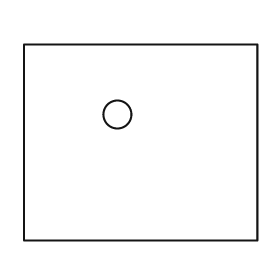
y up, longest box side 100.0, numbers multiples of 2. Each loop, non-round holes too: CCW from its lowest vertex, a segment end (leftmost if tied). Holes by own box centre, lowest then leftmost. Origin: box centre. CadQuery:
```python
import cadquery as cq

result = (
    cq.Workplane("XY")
    .moveTo(-50.0, -42.0)
    .lineTo(50.0, -42.0)
    .lineTo(50.0, 42.0)
    .lineTo(-50.0, 42.0)
    .close()
    .moveTo(-10.0, 12.0)
    .circle(6.0)
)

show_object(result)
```